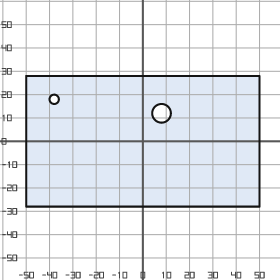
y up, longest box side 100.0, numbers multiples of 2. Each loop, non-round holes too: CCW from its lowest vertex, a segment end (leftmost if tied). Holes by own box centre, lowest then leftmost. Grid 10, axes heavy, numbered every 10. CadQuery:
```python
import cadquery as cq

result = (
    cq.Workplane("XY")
    .moveTo(-50.0, -28.0)
    .lineTo(50.0, -28.0)
    .lineTo(50.0, 28.0)
    .lineTo(-50.0, 28.0)
    .close()
    .moveTo(8.0, 12.0)
    .circle(4.0)
    .moveTo(-38.0, 18.0)
    .circle(2.0)
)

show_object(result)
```